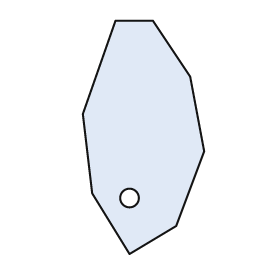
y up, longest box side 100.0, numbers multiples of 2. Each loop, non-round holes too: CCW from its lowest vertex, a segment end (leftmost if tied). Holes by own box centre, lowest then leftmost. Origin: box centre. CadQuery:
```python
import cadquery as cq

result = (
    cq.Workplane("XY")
    .moveTo(-6.0, -50.0)
    .lineTo(14.0, -38.0)
    .lineTo(26.0, -6.0)
    .lineTo(20.0, 26.0)
    .lineTo(4.0, 50.0)
    .lineTo(-12.0, 50.0)
    .lineTo(-26.0, 10.0)
    .lineTo(-22.0, -24.0)
    .close()
    .moveTo(-6.0, -26.0)
    .circle(4.0)
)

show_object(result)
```